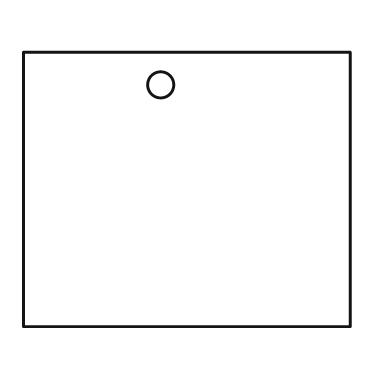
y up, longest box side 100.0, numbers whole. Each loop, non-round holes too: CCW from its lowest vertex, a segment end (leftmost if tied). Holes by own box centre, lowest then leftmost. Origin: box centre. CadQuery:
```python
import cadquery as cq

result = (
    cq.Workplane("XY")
    .moveTo(-50.0, -42.0)
    .lineTo(50.0, -42.0)
    .lineTo(50.0, 42.0)
    .lineTo(-50.0, 42.0)
    .close()
    .moveTo(-8.0, 32.0)
    .circle(4.0)
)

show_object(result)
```